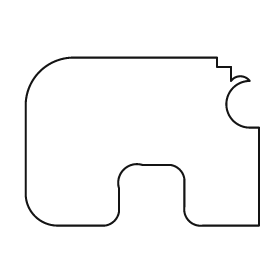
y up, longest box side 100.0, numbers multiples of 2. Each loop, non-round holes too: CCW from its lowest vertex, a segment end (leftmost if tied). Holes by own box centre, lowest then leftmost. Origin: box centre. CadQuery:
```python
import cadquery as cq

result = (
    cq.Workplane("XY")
    .moveTo(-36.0, -36.0)
    .lineTo(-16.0, -36.0)
    .threePointArc((-12.0, -34.0), (-10.0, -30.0))
    .lineTo(-10.0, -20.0)
    .threePointArc((-8.0, -12.0), (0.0, -10.0))
    .lineTo(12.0, -10.0)
    .threePointArc((16.0, -12.0), (18.0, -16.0))
    .lineTo(18.0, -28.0)
    .threePointArc((20.0, -34.0), (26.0, -36.0))
    .lineTo(50.0, -36.0)
    .lineTo(50.0, 6.0)
    .lineTo(46.0, 6.0)
    .threePointArc((36.0, 16.0), (46.0, 26.0))
    .threePointArc((42.0, 28.0), (38.0, 26.0))
    .lineTo(38.0, 32.0)
    .lineTo(32.0, 32.0)
    .lineTo(32.0, 36.0)
    .lineTo(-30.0, 36.0)
    .threePointArc((-44.0, 30.0), (-50.0, 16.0))
    .lineTo(-50.0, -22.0)
    .threePointArc((-46.0, -32.0), (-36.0, -36.0))
    .close()
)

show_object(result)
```